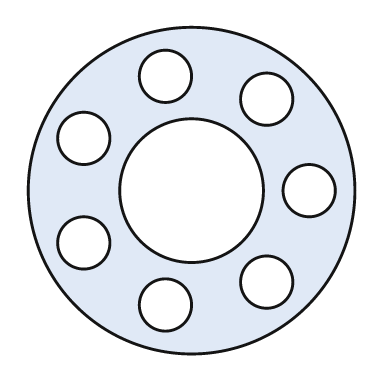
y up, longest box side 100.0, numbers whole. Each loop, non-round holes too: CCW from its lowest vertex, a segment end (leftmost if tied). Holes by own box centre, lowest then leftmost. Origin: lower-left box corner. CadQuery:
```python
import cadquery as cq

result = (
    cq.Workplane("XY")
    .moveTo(50.0, 50.0)
    .circle(50.0)
    .moveTo(42.0, 15.0)
    .circle(8.0)
    .moveTo(73.0, 22.0)
    .circle(8.0)
    .moveTo(17.0, 34.0)
    .circle(8.0)
    .moveTo(50.0, 50.0)
    .circle(22.0)
    .moveTo(86.0, 50.0)
    .circle(8.0)
    .moveTo(17.0, 66.0)
    .circle(8.0)
    .moveTo(73.0, 78.0)
    .circle(8.0)
    .moveTo(42.0, 85.0)
    .circle(8.0)
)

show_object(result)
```